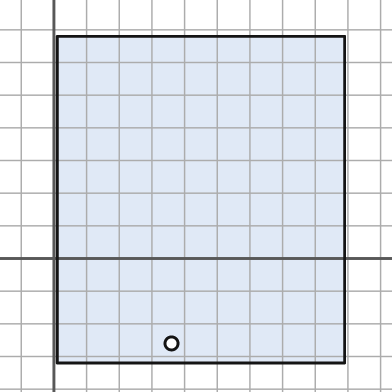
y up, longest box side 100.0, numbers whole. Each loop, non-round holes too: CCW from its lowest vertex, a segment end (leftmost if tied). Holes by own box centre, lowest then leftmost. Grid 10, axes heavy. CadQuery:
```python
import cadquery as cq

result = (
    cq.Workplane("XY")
    .moveTo(1.0, -32.0)
    .lineTo(89.0, -32.0)
    .lineTo(89.0, 68.0)
    .lineTo(1.0, 68.0)
    .close()
    .moveTo(36.0, -26.0)
    .circle(2.0)
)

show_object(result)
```